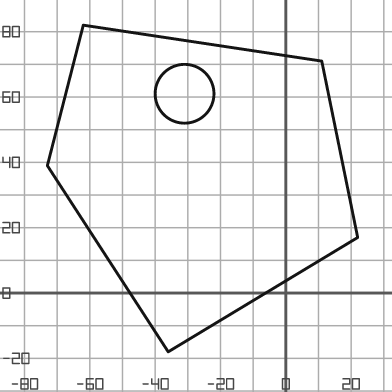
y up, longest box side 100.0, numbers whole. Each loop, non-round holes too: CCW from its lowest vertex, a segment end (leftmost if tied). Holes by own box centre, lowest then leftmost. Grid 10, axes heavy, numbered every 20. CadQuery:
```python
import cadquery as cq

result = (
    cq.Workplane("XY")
    .moveTo(-36.0, -18.0)
    .lineTo(22.0, 17.0)
    .lineTo(11.0, 71.0)
    .lineTo(-62.0, 82.0)
    .lineTo(-73.0, 39.0)
    .close()
    .moveTo(-31.0, 61.0)
    .circle(9.0)
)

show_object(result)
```